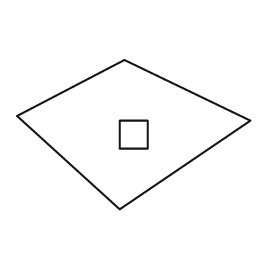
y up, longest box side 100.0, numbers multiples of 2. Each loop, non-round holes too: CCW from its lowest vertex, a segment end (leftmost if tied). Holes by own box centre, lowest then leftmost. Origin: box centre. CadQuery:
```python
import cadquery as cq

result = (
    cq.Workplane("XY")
    .moveTo(-6.0, -32.0)
    .lineTo(50.0, 6.0)
    .lineTo(-4.0, 32.0)
    .lineTo(-50.0, 8.0)
    .close()
    .moveTo(-6.0, -6.0)
    .lineTo(6.0, -6.0)
    .lineTo(6.0, 6.0)
    .lineTo(-6.0, 6.0)
    .close()
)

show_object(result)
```